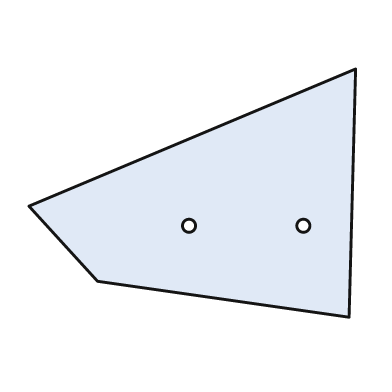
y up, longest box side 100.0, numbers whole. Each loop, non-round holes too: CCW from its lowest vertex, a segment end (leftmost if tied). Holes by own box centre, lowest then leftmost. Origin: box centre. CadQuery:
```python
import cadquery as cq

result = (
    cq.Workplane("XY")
    .moveTo(48.0, -38.0)
    .lineTo(50.0, 38.0)
    .lineTo(-50.0, -4.0)
    .lineTo(-29.0, -27.0)
    .close()
    .moveTo(-1.0, -10.0)
    .circle(2.0)
    .moveTo(34.0, -10.0)
    .circle(2.0)
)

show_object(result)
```